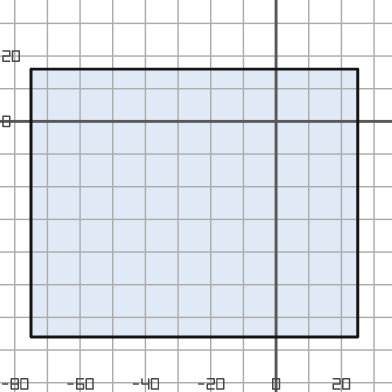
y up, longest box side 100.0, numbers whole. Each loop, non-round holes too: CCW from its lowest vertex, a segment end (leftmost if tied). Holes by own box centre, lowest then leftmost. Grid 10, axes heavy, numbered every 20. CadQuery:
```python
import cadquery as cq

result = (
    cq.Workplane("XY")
    .moveTo(-75.0, -66.0)
    .lineTo(25.0, -66.0)
    .lineTo(25.0, 16.0)
    .lineTo(-75.0, 16.0)
    .close()
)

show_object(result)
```